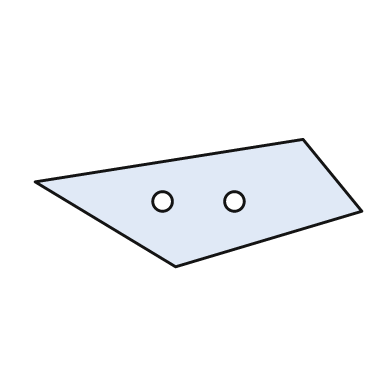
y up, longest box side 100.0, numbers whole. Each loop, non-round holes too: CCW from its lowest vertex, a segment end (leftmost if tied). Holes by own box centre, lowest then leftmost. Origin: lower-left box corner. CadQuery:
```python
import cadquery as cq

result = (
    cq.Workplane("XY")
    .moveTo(43.0, 0.0)
    .lineTo(100.0, 17.0)
    .lineTo(82.0, 39.0)
    .lineTo(0.0, 26.0)
    .close()
    .moveTo(39.0, 20.0)
    .circle(3.0)
    .moveTo(61.0, 20.0)
    .circle(3.0)
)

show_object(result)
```